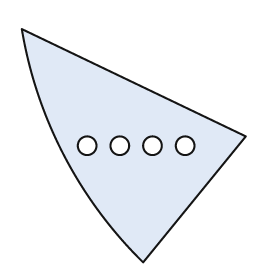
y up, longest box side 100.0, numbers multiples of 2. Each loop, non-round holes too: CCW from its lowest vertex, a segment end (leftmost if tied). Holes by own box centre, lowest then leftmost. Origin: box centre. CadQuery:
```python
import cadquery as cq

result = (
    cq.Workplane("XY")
    .moveTo(4.0, -50.0)
    .lineTo(48.0, 4.0)
    .lineTo(-48.0, 50.0)
    .threePointArc((-30.0, -4.0), (4.0, -50.0))
    .close()
    .moveTo(-20.0, 0.0)
    .circle(4.0)
    .moveTo(-6.0, 0.0)
    .circle(4.0)
    .moveTo(8.0, 0.0)
    .circle(4.0)
    .moveTo(22.0, 0.0)
    .circle(4.0)
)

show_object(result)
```